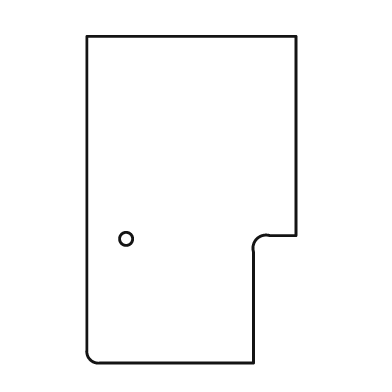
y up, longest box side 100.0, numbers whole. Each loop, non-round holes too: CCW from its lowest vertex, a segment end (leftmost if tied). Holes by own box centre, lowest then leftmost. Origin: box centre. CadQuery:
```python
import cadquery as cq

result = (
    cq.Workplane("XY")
    .moveTo(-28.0, -50.0)
    .lineTo(19.0, -50.0)
    .lineTo(19.0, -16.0)
    .threePointArc((20.0, -12.0), (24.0, -11.0))
    .lineTo(32.0, -11.0)
    .lineTo(32.0, 50.0)
    .lineTo(-32.0, 50.0)
    .lineTo(-32.0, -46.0)
    .threePointArc((-31.0, -49.0), (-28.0, -50.0))
    .close()
    .moveTo(-20.0, -12.0)
    .circle(2.0)
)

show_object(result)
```